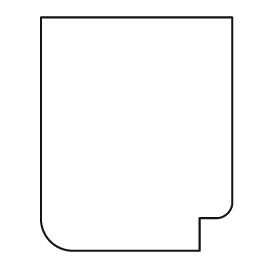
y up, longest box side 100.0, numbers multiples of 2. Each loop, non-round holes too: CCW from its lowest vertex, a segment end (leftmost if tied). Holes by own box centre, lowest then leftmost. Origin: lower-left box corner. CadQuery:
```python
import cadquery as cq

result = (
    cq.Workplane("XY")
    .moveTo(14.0, 0.0)
    .lineTo(68.0, 0.0)
    .lineTo(68.0, 14.0)
    .lineTo(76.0, 14.0)
    .threePointArc((80.0, 16.0), (82.0, 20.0))
    .lineTo(82.0, 100.0)
    .lineTo(0.0, 100.0)
    .lineTo(0.0, 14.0)
    .threePointArc((4.0, 4.0), (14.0, 0.0))
    .close()
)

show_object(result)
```